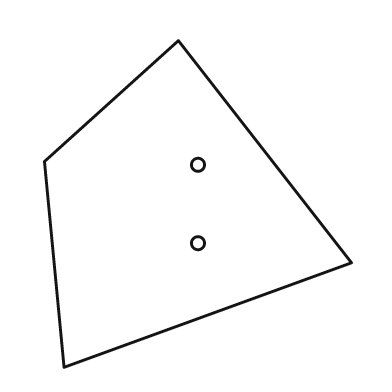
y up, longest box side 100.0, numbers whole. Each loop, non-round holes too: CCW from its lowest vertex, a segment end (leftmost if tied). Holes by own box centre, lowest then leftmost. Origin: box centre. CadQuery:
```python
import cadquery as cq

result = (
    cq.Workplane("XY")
    .moveTo(-41.0, -50.0)
    .lineTo(47.0, -18.0)
    .lineTo(-6.0, 50.0)
    .lineTo(-47.0, 13.0)
    .close()
    .moveTo(0.0, -12.0)
    .circle(2.0)
    .moveTo(0.0, 12.0)
    .circle(2.0)
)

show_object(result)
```